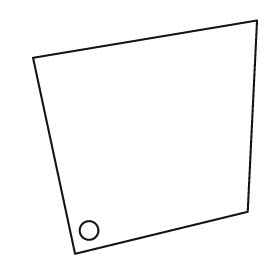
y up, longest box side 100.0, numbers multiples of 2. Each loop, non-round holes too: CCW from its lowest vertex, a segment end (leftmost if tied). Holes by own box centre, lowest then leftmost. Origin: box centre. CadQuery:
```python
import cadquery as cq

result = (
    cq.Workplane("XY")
    .moveTo(-30.0, -50.0)
    .lineTo(44.0, -32.0)
    .lineTo(48.0, 50.0)
    .lineTo(-48.0, 34.0)
    .close()
    .moveTo(-24.0, -40.0)
    .circle(4.0)
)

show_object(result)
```